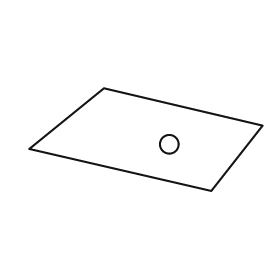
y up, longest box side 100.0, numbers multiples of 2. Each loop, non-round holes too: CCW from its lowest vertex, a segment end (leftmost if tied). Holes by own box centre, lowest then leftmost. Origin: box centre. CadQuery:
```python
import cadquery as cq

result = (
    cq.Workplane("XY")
    .moveTo(28.0, -22.0)
    .lineTo(50.0, 6.0)
    .lineTo(-18.0, 22.0)
    .lineTo(-50.0, -4.0)
    .close()
    .moveTo(10.0, -2.0)
    .circle(4.0)
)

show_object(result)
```